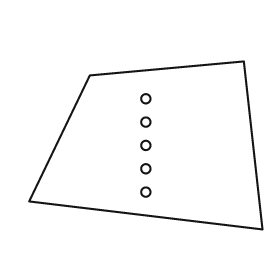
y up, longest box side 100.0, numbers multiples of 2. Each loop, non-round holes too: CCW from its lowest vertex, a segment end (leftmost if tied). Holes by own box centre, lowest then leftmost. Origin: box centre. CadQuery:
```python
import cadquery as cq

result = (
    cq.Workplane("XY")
    .moveTo(50.0, -36.0)
    .lineTo(42.0, 36.0)
    .lineTo(-24.0, 30.0)
    .lineTo(-50.0, -24.0)
    .close()
    .moveTo(0.0, -20.0)
    .circle(2.0)
    .moveTo(0.0, -10.0)
    .circle(2.0)
    .moveTo(0.0, 0.0)
    .circle(2.0)
    .moveTo(0.0, 10.0)
    .circle(2.0)
    .moveTo(0.0, 20.0)
    .circle(2.0)
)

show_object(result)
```